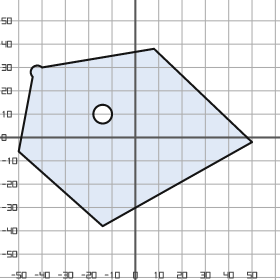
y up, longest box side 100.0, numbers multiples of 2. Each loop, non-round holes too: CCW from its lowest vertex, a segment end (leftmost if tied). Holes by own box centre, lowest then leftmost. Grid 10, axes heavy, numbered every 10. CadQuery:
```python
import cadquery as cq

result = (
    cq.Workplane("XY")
    .moveTo(-14.0, -38.0)
    .lineTo(50.0, -2.0)
    .lineTo(8.0, 38.0)
    .lineTo(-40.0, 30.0)
    .threePointArc((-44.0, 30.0), (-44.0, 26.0))
    .lineTo(-50.0, -6.0)
    .close()
    .moveTo(-14.0, 10.0)
    .circle(4.0)
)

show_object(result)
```